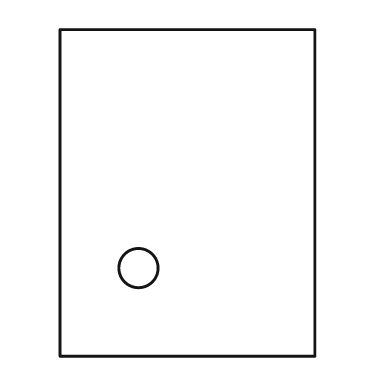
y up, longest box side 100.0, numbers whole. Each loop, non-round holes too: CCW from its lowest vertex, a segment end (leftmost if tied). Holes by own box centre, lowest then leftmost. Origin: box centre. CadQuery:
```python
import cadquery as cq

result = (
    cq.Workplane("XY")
    .moveTo(-39.0, -50.0)
    .lineTo(39.0, -50.0)
    .lineTo(39.0, 50.0)
    .lineTo(-39.0, 50.0)
    .close()
    .moveTo(-15.0, -23.0)
    .circle(6.0)
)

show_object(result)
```